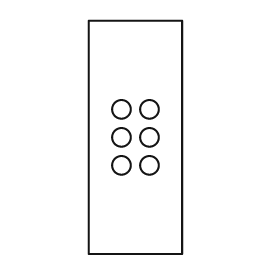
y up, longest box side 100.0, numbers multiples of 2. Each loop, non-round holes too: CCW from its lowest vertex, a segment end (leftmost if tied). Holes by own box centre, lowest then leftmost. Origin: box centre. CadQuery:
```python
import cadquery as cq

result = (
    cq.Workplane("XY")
    .moveTo(-20.0, -50.0)
    .lineTo(20.0, -50.0)
    .lineTo(20.0, 50.0)
    .lineTo(-20.0, 50.0)
    .close()
    .moveTo(-6.0, -12.0)
    .circle(4.0)
    .moveTo(6.0, -12.0)
    .circle(4.0)
    .moveTo(-6.0, 0.0)
    .circle(4.0)
    .moveTo(6.0, 0.0)
    .circle(4.0)
    .moveTo(-6.0, 12.0)
    .circle(4.0)
    .moveTo(6.0, 12.0)
    .circle(4.0)
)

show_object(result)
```